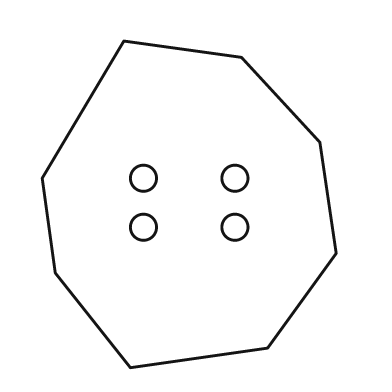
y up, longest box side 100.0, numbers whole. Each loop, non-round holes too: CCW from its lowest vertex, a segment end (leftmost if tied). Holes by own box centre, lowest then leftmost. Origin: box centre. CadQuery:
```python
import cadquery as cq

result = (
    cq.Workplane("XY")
    .moveTo(-18.0, -50.0)
    .lineTo(24.0, -44.0)
    .lineTo(45.0, -15.0)
    .lineTo(40.0, 19.0)
    .lineTo(16.0, 45.0)
    .lineTo(-20.0, 50.0)
    .lineTo(-45.0, 8.0)
    .lineTo(-41.0, -21.0)
    .close()
    .moveTo(-14.0, -7.0)
    .circle(4.0)
    .moveTo(14.0, -7.0)
    .circle(4.0)
    .moveTo(-14.0, 8.0)
    .circle(4.0)
    .moveTo(14.0, 8.0)
    .circle(4.0)
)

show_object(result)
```